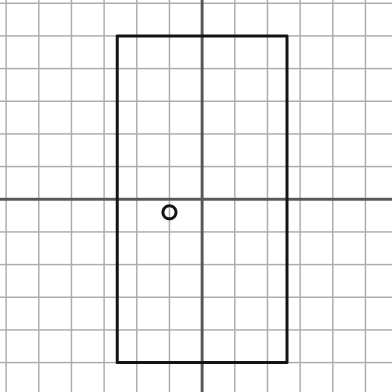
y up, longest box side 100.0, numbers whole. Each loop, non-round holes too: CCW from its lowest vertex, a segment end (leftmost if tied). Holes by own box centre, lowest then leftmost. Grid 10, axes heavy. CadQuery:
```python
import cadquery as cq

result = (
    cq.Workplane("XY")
    .moveTo(-26.0, -50.0)
    .lineTo(26.0, -50.0)
    .lineTo(26.0, 50.0)
    .lineTo(-26.0, 50.0)
    .close()
    .moveTo(-10.0, -4.0)
    .circle(2.0)
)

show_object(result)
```